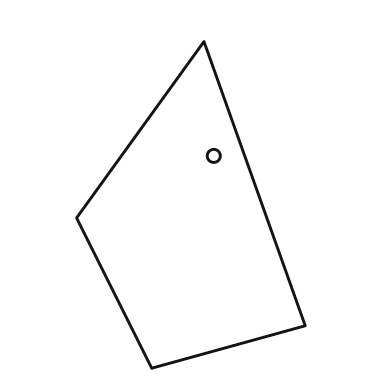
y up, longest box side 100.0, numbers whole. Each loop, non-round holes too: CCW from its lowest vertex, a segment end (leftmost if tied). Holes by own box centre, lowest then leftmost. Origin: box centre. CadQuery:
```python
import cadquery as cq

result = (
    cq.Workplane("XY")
    .moveTo(-12.0, -50.0)
    .lineTo(35.0, -37.0)
    .lineTo(4.0, 50.0)
    .lineTo(-35.0, -4.0)
    .close()
    .moveTo(7.0, 15.0)
    .circle(2.0)
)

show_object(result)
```